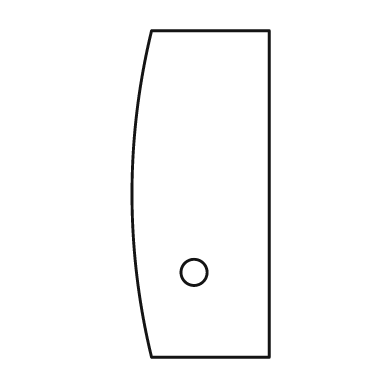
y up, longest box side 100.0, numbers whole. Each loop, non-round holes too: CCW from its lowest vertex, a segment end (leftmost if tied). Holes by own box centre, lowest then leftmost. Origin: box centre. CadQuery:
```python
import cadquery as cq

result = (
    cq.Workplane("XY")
    .moveTo(-15.0, -50.0)
    .lineTo(21.0, -50.0)
    .lineTo(21.0, 50.0)
    .lineTo(-15.0, 50.0)
    .threePointArc((-21.0, 0.0), (-15.0, -50.0))
    .close()
    .moveTo(-2.0, -24.0)
    .circle(4.0)
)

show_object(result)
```